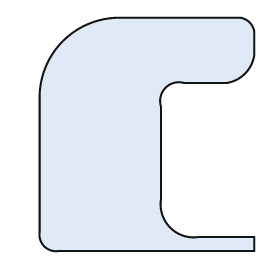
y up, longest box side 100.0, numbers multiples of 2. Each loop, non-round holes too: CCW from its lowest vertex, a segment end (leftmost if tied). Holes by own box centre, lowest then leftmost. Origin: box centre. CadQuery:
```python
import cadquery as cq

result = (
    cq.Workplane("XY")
    .moveTo(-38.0, -50.0)
    .lineTo(46.0, -50.0)
    .lineTo(46.0, -44.0)
    .lineTo(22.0, -44.0)
    .threePointArc((10.0, -40.0), (6.0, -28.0))
    .lineTo(6.0, 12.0)
    .threePointArc((8.0, 20.0), (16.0, 22.0))
    .lineTo(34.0, 22.0)
    .threePointArc((42.0, 26.0), (46.0, 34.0))
    .lineTo(46.0, 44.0)
    .threePointArc((44.0, 48.0), (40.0, 50.0))
    .lineTo(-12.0, 50.0)
    .threePointArc((-36.0, 40.0), (-46.0, 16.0))
    .lineTo(-46.0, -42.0)
    .threePointArc((-44.0, -48.0), (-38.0, -50.0))
    .close()
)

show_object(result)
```